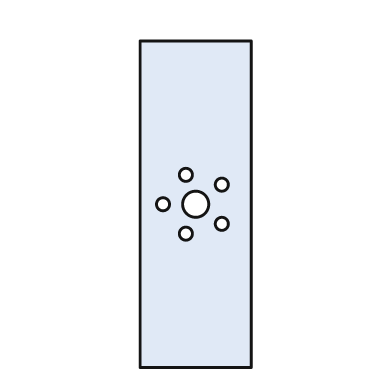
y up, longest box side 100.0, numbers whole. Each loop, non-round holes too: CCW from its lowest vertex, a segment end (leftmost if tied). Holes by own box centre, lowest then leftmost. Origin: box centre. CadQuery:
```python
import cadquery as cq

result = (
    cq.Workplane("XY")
    .moveTo(-17.0, -50.0)
    .lineTo(17.0, -50.0)
    .lineTo(17.0, 50.0)
    .lineTo(-17.0, 50.0)
    .close()
    .moveTo(-3.0, -9.0)
    .circle(2.0)
    .moveTo(8.0, -6.0)
    .circle(2.0)
    .moveTo(-10.0, 0.0)
    .circle(2.0)
    .moveTo(0.0, 0.0)
    .circle(4.0)
    .moveTo(8.0, 6.0)
    .circle(2.0)
    .moveTo(-3.0, 9.0)
    .circle(2.0)
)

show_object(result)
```